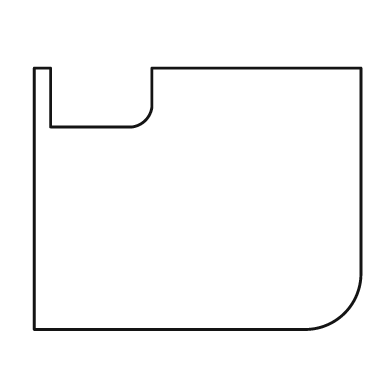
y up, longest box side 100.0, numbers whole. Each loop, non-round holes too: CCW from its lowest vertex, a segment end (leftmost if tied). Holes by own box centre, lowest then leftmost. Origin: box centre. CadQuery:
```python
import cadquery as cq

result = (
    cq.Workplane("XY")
    .moveTo(-50.0, -40.0)
    .lineTo(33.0, -40.0)
    .threePointArc((45.0, -35.0), (50.0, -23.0))
    .lineTo(50.0, 40.0)
    .lineTo(-14.0, 40.0)
    .lineTo(-14.0, 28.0)
    .threePointArc((-16.0, 24.0), (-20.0, 22.0))
    .lineTo(-45.0, 22.0)
    .lineTo(-45.0, 40.0)
    .lineTo(-50.0, 40.0)
    .close()
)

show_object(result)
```